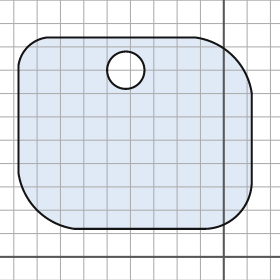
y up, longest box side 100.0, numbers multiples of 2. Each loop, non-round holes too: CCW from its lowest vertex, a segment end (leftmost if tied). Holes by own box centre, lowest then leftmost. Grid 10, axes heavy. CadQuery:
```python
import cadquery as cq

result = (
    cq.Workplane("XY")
    .moveTo(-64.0, 12.0)
    .lineTo(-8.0, 12.0)
    .threePointArc((6.0, 18.0), (12.0, 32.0))
    .lineTo(12.0, 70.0)
    .threePointArc((4.0, 86.0), (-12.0, 94.0))
    .lineTo(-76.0, 94.0)
    .threePointArc((-84.0, 90.0), (-88.0, 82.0))
    .lineTo(-88.0, 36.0)
    .threePointArc((-80.0, 20.0), (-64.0, 12.0))
    .close()
    .moveTo(-42.0, 80.0)
    .circle(8.0)
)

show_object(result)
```